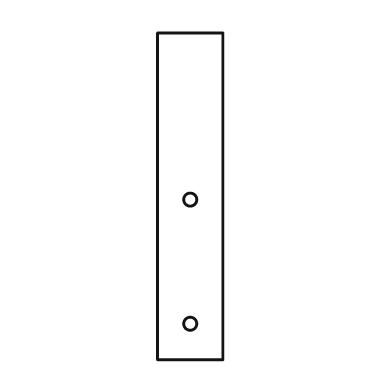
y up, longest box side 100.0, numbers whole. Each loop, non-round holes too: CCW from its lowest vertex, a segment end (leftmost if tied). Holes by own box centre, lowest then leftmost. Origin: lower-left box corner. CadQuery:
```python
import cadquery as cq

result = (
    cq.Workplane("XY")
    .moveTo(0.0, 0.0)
    .lineTo(20.0, 0.0)
    .lineTo(20.0, 100.0)
    .lineTo(0.0, 100.0)
    .close()
    .moveTo(10.0, 11.0)
    .circle(2.0)
    .moveTo(10.0, 49.0)
    .circle(2.0)
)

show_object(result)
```